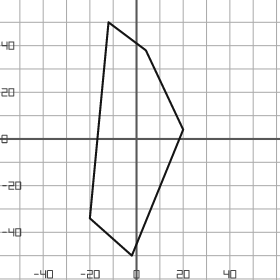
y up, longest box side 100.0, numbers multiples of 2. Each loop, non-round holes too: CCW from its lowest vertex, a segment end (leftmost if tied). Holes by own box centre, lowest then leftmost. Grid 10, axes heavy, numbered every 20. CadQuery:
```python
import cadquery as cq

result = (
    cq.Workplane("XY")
    .moveTo(-2.0, -50.0)
    .lineTo(20.0, 4.0)
    .lineTo(4.0, 38.0)
    .lineTo(-12.0, 50.0)
    .lineTo(-20.0, -34.0)
    .close()
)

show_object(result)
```